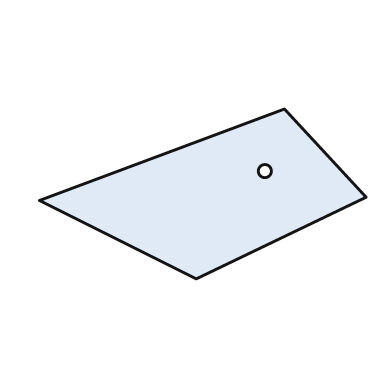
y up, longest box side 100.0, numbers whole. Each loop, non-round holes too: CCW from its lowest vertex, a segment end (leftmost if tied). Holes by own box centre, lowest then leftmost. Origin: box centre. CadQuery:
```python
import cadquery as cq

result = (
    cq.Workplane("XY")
    .moveTo(-2.0, -26.0)
    .lineTo(50.0, -1.0)
    .lineTo(25.0, 26.0)
    .lineTo(-50.0, -2.0)
    .close()
    .moveTo(19.0, 7.0)
    .circle(2.0)
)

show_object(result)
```